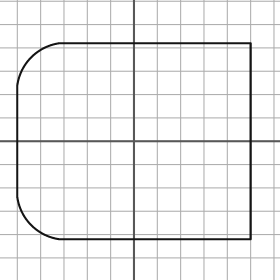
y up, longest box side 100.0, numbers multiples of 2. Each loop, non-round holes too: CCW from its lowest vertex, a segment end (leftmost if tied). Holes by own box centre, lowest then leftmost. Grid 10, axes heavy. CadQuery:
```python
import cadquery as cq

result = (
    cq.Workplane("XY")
    .moveTo(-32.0, -42.0)
    .lineTo(50.0, -42.0)
    .lineTo(50.0, 42.0)
    .lineTo(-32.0, 42.0)
    .threePointArc((-44.0, 36.0), (-50.0, 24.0))
    .lineTo(-50.0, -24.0)
    .threePointArc((-44.0, -36.0), (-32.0, -42.0))
    .close()
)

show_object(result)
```